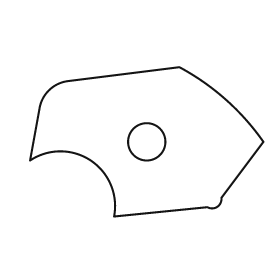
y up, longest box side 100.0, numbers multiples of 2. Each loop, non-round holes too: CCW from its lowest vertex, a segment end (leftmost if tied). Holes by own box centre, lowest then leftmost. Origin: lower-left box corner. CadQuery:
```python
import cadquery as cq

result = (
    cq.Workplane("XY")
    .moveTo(36.0, 0.0)
    .lineTo(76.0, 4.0)
    .threePointArc((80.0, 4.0), (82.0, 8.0))
    .lineTo(100.0, 32.0)
    .threePointArc((84.0, 50.0), (64.0, 64.0))
    .lineTo(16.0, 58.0)
    .threePointArc((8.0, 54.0), (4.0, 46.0))
    .lineTo(0.0, 24.0)
    .threePointArc((26.0, 24.0), (36.0, 0.0))
    .close()
    .moveTo(50.0, 32.0)
    .circle(8.0)
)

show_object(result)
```